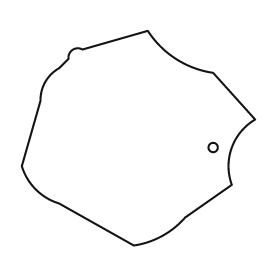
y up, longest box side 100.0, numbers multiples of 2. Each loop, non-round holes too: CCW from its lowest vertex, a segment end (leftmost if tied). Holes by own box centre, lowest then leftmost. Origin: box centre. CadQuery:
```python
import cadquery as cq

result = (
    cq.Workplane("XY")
    .moveTo(-2.0, -46.0)
    .threePointArc((10.0, -42.0), (20.0, -34.0))
    .lineTo(40.0, -20.0)
    .threePointArc((40.0, -4.0), (50.0, 8.0))
    .lineTo(32.0, 28.0)
    .threePointArc((16.0, 34.0), (4.0, 46.0))
    .lineTo(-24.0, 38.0)
    .threePointArc((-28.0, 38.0), (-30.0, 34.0))
    .lineTo(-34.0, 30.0)
    .threePointArc((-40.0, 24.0), (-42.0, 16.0))
    .lineTo(-50.0, -12.0)
    .threePointArc((-44.0, -22.0), (-34.0, -28.0))
    .close()
    .moveTo(32.0, -4.0)
    .circle(2.0)
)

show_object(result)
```